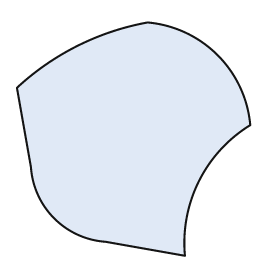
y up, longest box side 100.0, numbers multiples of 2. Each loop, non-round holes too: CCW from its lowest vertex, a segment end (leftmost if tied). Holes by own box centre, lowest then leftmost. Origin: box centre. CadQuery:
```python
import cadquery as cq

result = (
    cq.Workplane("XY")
    .moveTo(22.0, -50.0)
    .threePointArc((28.0, -18.0), (50.0, 6.0))
    .threePointArc((36.0, 36.0), (6.0, 50.0))
    .threePointArc((-24.0, 40.0), (-50.0, 22.0))
    .lineTo(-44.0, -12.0)
    .threePointArc((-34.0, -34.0), (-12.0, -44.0))
    .close()
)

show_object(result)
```